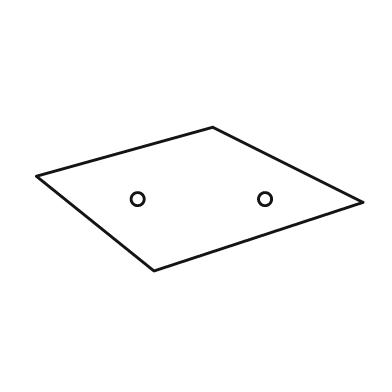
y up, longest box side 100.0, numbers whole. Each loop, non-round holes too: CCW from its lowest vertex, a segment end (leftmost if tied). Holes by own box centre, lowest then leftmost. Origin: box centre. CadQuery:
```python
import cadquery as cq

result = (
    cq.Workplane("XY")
    .moveTo(-14.0, -22.0)
    .lineTo(50.0, -1.0)
    .lineTo(4.0, 22.0)
    .lineTo(-50.0, 7.0)
    .close()
    .moveTo(-19.0, 0.0)
    .circle(2.0)
    .moveTo(20.0, 0.0)
    .circle(2.0)
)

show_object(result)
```